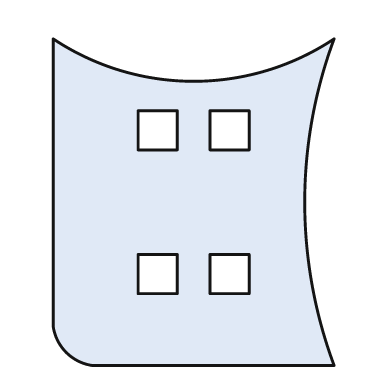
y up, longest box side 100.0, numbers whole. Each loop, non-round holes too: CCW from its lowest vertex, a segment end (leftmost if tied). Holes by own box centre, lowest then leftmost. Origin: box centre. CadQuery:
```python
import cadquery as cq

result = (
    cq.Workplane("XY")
    .moveTo(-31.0, -50.0)
    .lineTo(43.0, -50.0)
    .threePointArc((34.0, 0.0), (43.0, 50.0))
    .threePointArc((0.0, 37.0), (-43.0, 50.0))
    .lineTo(-43.0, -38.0)
    .threePointArc((-39.0, -46.0), (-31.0, -50.0))
    .close()
    .moveTo(-17.0, -28.0)
    .lineTo(-5.0, -28.0)
    .lineTo(-5.0, -16.0)
    .lineTo(-17.0, -16.0)
    .close()
    .moveTo(5.0, -28.0)
    .lineTo(17.0, -28.0)
    .lineTo(17.0, -16.0)
    .lineTo(5.0, -16.0)
    .close()
    .moveTo(-17.0, 16.0)
    .lineTo(-5.0, 16.0)
    .lineTo(-5.0, 28.0)
    .lineTo(-17.0, 28.0)
    .close()
    .moveTo(5.0, 16.0)
    .lineTo(17.0, 16.0)
    .lineTo(17.0, 28.0)
    .lineTo(5.0, 28.0)
    .close()
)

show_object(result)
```